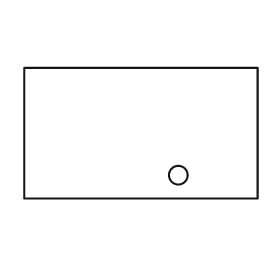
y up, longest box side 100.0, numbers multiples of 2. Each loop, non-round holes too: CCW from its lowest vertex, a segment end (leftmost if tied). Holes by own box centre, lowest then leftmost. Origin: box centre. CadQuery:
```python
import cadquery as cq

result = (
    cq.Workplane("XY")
    .moveTo(-50.0, -28.0)
    .lineTo(50.0, -28.0)
    .lineTo(50.0, 28.0)
    .lineTo(-50.0, 28.0)
    .close()
    .moveTo(16.0, -18.0)
    .circle(4.0)
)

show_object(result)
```